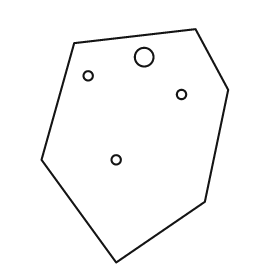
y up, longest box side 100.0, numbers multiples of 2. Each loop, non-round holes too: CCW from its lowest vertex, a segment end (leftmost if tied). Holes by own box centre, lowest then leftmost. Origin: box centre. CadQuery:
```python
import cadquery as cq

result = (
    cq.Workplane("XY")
    .moveTo(-8.0, -50.0)
    .lineTo(30.0, -24.0)
    .lineTo(40.0, 24.0)
    .lineTo(26.0, 50.0)
    .lineTo(-26.0, 44.0)
    .lineTo(-40.0, -6.0)
    .close()
    .moveTo(-8.0, -6.0)
    .circle(2.0)
    .moveTo(20.0, 22.0)
    .circle(2.0)
    .moveTo(-20.0, 30.0)
    .circle(2.0)
    .moveTo(4.0, 38.0)
    .circle(4.0)
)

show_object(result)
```